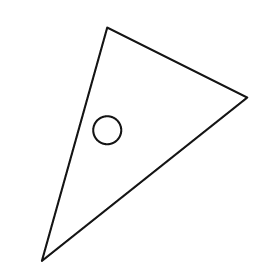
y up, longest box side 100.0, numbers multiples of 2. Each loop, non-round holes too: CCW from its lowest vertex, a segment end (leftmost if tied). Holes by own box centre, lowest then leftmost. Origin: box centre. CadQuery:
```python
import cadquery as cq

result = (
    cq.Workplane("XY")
    .moveTo(-44.0, -50.0)
    .lineTo(44.0, 20.0)
    .lineTo(-16.0, 50.0)
    .close()
    .moveTo(-16.0, 6.0)
    .circle(6.0)
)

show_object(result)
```